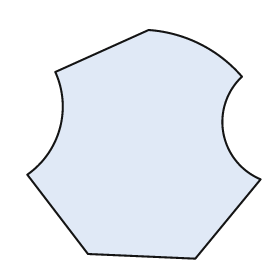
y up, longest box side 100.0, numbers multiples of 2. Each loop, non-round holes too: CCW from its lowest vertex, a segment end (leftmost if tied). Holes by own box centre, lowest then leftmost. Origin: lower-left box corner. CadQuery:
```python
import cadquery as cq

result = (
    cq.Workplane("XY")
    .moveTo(72.0, 0.0)
    .lineTo(100.0, 34.0)
    .threePointArc((84.0, 54.0), (92.0, 78.0))
    .threePointArc((74.0, 92.0), (52.0, 98.0))
    .lineTo(12.0, 80.0)
    .threePointArc((14.0, 56.0), (0.0, 36.0))
    .lineTo(26.0, 2.0)
    .close()
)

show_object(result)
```